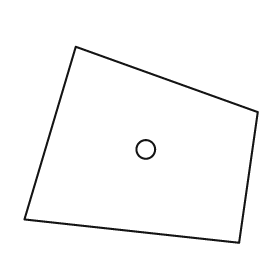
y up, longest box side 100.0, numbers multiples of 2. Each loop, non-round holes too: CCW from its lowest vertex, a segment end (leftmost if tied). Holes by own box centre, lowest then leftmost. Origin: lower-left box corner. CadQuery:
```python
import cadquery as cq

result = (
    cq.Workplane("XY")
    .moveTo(92.0, 0.0)
    .lineTo(100.0, 56.0)
    .lineTo(22.0, 84.0)
    .lineTo(0.0, 10.0)
    .close()
    .moveTo(52.0, 40.0)
    .circle(4.0)
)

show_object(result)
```